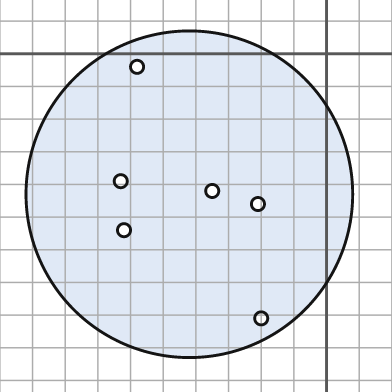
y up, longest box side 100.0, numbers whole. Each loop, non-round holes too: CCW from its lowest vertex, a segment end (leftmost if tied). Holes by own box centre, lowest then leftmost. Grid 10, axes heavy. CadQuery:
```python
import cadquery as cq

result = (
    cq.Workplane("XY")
    .moveTo(-42.0, -43.0)
    .circle(50.0)
    .moveTo(-20.0, -81.0)
    .circle(2.0)
    .moveTo(-62.0, -54.0)
    .circle(2.0)
    .moveTo(-21.0, -46.0)
    .circle(2.0)
    .moveTo(-35.0, -42.0)
    .circle(2.0)
    .moveTo(-63.0, -39.0)
    .circle(2.0)
    .moveTo(-58.0, -4.0)
    .circle(2.0)
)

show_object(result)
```